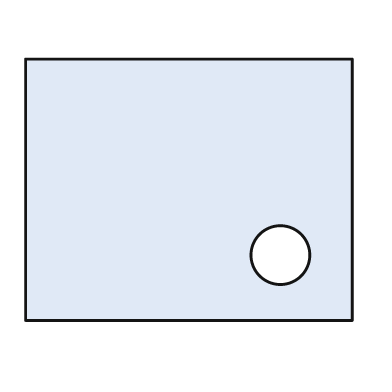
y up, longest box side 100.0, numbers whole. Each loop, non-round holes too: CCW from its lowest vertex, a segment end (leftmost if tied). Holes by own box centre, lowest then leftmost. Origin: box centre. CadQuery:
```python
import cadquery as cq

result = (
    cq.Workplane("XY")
    .moveTo(-50.0, -40.0)
    .lineTo(50.0, -40.0)
    .lineTo(50.0, 40.0)
    .lineTo(-50.0, 40.0)
    .close()
    .moveTo(28.0, -20.0)
    .circle(9.0)
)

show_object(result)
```